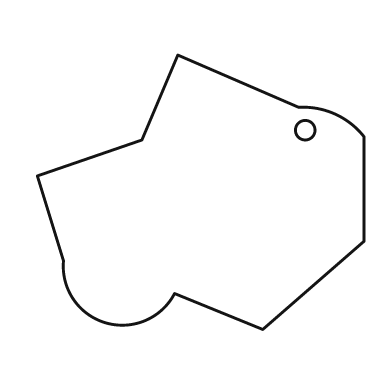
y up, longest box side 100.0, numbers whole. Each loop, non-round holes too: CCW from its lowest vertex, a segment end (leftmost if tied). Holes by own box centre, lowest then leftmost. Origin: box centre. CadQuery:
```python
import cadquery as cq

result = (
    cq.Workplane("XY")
    .moveTo(19.0, -42.0)
    .lineTo(50.0, -15.0)
    .lineTo(50.0, 17.0)
    .threePointArc((41.0, 24.0), (30.0, 26.0))
    .lineTo(-7.0, 42.0)
    .lineTo(-18.0, 16.0)
    .lineTo(-50.0, 5.0)
    .lineTo(-42.0, -21.0)
    .threePointArc((-29.0, -40.0), (-8.0, -31.0))
    .close()
    .moveTo(32.0, 19.0)
    .circle(3.0)
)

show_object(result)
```